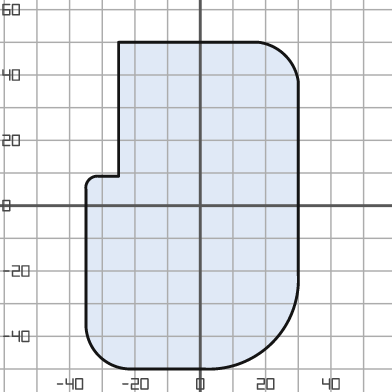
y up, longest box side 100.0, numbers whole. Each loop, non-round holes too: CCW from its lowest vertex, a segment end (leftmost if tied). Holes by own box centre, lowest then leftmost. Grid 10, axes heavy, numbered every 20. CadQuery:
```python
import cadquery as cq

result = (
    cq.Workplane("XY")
    .moveTo(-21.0, -50.0)
    .lineTo(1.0, -50.0)
    .threePointArc((22.0, -42.0), (30.0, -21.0))
    .lineTo(30.0, 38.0)
    .threePointArc((26.0, 46.0), (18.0, 50.0))
    .lineTo(-25.0, 50.0)
    .lineTo(-25.0, 9.0)
    .lineTo(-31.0, 9.0)
    .threePointArc((-34.0, 8.0), (-35.0, 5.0))
    .lineTo(-35.0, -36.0)
    .threePointArc((-31.0, -46.0), (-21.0, -50.0))
    .close()
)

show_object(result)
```